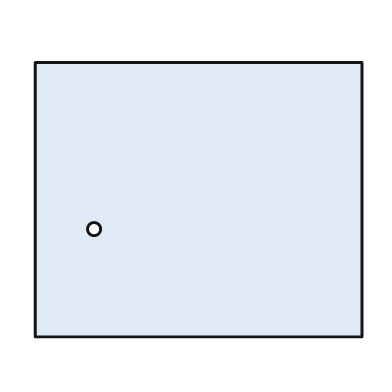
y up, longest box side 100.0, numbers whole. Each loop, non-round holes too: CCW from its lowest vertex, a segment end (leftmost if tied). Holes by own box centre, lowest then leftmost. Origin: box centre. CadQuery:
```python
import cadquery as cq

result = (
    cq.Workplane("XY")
    .moveTo(-50.0, -42.0)
    .lineTo(50.0, -42.0)
    .lineTo(50.0, 42.0)
    .lineTo(-50.0, 42.0)
    .close()
    .moveTo(-32.0, -9.0)
    .circle(2.0)
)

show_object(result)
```